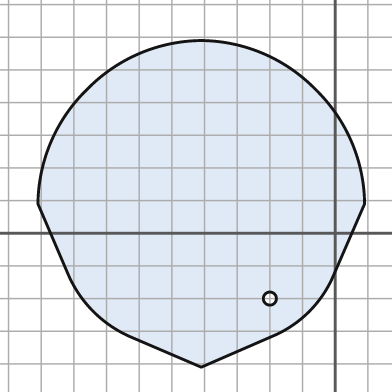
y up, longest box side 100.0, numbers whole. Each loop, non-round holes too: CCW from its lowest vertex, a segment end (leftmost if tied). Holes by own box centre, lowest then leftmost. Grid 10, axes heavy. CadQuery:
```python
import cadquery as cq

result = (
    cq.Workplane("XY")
    .moveTo(-41.0, -41.0)
    .lineTo(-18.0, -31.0)
    .threePointArc((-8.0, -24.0), (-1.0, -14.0))
    .lineTo(9.0, 9.0)
    .threePointArc((5.0, 28.0), (-6.0, 44.0))
    .threePointArc((-22.0, 55.0), (-41.0, 59.0))
    .threePointArc((-60.0, 55.0), (-76.0, 44.0))
    .threePointArc((-87.0, 28.0), (-91.0, 9.0))
    .lineTo(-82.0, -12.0)
    .threePointArc((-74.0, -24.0), (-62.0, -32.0))
    .close()
    .moveTo(-20.0, -20.0)
    .circle(2.0)
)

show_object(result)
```